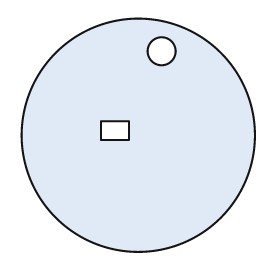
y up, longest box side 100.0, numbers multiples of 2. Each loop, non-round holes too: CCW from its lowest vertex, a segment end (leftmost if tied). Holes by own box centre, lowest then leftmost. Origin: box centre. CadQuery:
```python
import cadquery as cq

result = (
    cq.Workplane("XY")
    .moveTo(0.0, 0.0)
    .circle(50.0)
    .moveTo(-16.0, -2.0)
    .lineTo(-4.0, -2.0)
    .lineTo(-4.0, 6.0)
    .lineTo(-16.0, 6.0)
    .close()
    .moveTo(10.0, 36.0)
    .circle(6.0)
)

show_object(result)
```